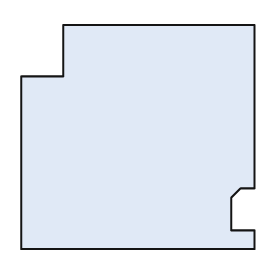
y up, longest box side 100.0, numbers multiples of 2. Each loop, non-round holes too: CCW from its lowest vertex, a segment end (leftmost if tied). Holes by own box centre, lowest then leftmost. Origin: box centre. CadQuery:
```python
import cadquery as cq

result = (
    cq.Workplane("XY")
    .moveTo(-50.0, -48.0)
    .lineTo(50.0, -48.0)
    .lineTo(50.0, -40.0)
    .lineTo(40.0, -40.0)
    .lineTo(40.0, -26.0)
    .lineTo(44.0, -22.0)
    .lineTo(50.0, -22.0)
    .lineTo(50.0, 48.0)
    .lineTo(-32.0, 48.0)
    .lineTo(-32.0, 26.0)
    .lineTo(-50.0, 26.0)
    .close()
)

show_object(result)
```